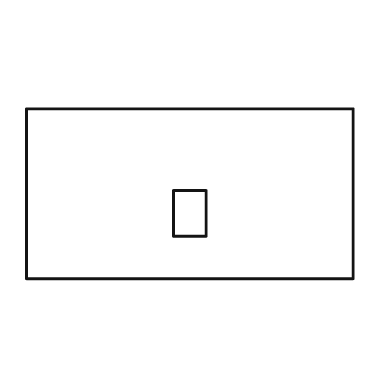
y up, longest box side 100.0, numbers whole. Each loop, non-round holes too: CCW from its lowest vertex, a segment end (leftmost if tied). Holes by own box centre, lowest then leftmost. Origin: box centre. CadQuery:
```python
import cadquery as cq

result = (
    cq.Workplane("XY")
    .moveTo(-50.0, -26.0)
    .lineTo(50.0, -26.0)
    .lineTo(50.0, 26.0)
    .lineTo(-50.0, 26.0)
    .close()
    .moveTo(-5.0, -13.0)
    .lineTo(5.0, -13.0)
    .lineTo(5.0, 1.0)
    .lineTo(-5.0, 1.0)
    .close()
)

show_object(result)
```